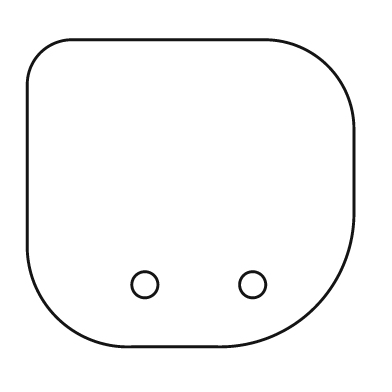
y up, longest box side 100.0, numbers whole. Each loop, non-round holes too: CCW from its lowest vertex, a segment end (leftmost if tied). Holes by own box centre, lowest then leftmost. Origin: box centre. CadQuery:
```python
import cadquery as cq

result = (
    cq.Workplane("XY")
    .moveTo(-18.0, -47.0)
    .lineTo(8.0, -47.0)
    .threePointArc((38.0, -35.0), (50.0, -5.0))
    .lineTo(50.0, 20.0)
    .threePointArc((42.0, 39.0), (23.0, 47.0))
    .lineTo(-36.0, 47.0)
    .threePointArc((-46.0, 43.0), (-50.0, 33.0))
    .lineTo(-50.0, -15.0)
    .threePointArc((-41.0, -38.0), (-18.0, -47.0))
    .close()
    .moveTo(-14.0, -28.0)
    .circle(4.0)
    .moveTo(19.0, -28.0)
    .circle(4.0)
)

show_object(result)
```